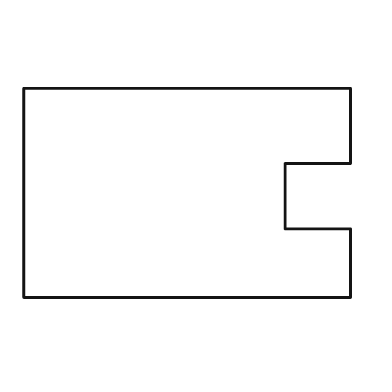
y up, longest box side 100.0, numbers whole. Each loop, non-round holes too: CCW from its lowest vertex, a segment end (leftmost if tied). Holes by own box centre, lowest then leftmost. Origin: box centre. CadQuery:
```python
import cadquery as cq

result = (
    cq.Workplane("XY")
    .moveTo(-50.0, -32.0)
    .lineTo(50.0, -32.0)
    .lineTo(50.0, -11.0)
    .lineTo(30.0, -11.0)
    .lineTo(30.0, 9.0)
    .lineTo(50.0, 9.0)
    .lineTo(50.0, 32.0)
    .lineTo(-50.0, 32.0)
    .close()
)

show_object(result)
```